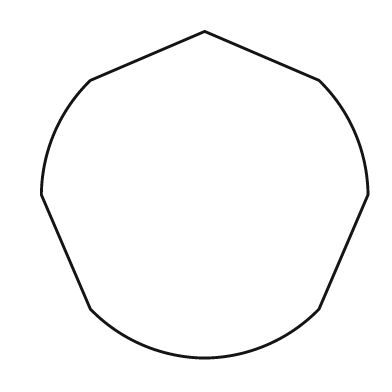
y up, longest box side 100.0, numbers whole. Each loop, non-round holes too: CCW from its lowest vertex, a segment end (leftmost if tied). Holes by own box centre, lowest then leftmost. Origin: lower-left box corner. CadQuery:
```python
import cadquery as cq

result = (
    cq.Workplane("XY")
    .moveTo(50.0, 0.0)
    .threePointArc((69.0, 4.0), (85.0, 15.0))
    .lineTo(100.0, 50.0)
    .threePointArc((96.0, 69.0), (85.0, 85.0))
    .lineTo(50.0, 100.0)
    .lineTo(15.0, 85.0)
    .threePointArc((4.0, 69.0), (0.0, 50.0))
    .lineTo(15.0, 15.0)
    .threePointArc((31.0, 4.0), (50.0, 0.0))
    .close()
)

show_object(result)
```